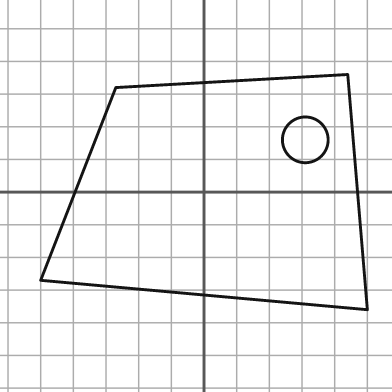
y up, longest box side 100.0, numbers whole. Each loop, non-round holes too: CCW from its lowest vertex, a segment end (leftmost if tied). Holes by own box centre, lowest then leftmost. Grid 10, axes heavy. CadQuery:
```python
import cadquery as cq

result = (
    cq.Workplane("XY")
    .moveTo(50.0, -36.0)
    .lineTo(44.0, 36.0)
    .lineTo(-27.0, 32.0)
    .lineTo(-50.0, -27.0)
    .close()
    .moveTo(31.0, 16.0)
    .circle(7.0)
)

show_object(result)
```